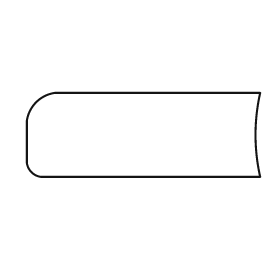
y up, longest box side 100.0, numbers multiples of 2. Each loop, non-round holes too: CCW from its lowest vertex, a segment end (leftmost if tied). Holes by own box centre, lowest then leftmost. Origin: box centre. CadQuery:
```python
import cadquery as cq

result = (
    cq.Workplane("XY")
    .moveTo(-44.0, -18.0)
    .lineTo(50.0, -18.0)
    .threePointArc((48.0, 0.0), (50.0, 18.0))
    .lineTo(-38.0, 18.0)
    .threePointArc((-46.0, 14.0), (-50.0, 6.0))
    .lineTo(-50.0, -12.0)
    .threePointArc((-48.0, -16.0), (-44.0, -18.0))
    .close()
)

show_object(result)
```